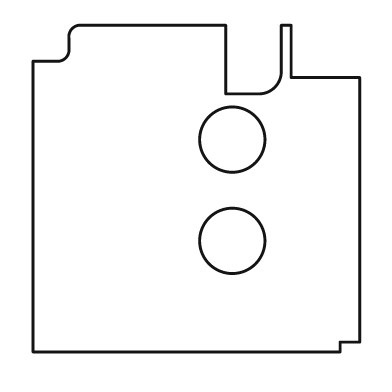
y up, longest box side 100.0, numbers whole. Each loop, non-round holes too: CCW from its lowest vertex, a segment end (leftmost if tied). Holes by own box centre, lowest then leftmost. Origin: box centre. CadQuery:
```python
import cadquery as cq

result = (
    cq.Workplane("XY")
    .moveTo(-50.0, -50.0)
    .lineTo(44.0, -50.0)
    .lineTo(44.0, -47.0)
    .lineTo(50.0, -47.0)
    .lineTo(50.0, 34.0)
    .lineTo(29.0, 34.0)
    .lineTo(29.0, 50.0)
    .lineTo(26.0, 50.0)
    .lineTo(26.0, 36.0)
    .threePointArc((24.0, 31.0), (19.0, 29.0))
    .lineTo(9.0, 29.0)
    .lineTo(9.0, 50.0)
    .lineTo(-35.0, 50.0)
    .threePointArc((-38.0, 49.0), (-39.0, 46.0))
    .lineTo(-39.0, 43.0)
    .threePointArc((-40.0, 40.0), (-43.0, 39.0))
    .lineTo(-50.0, 39.0)
    .close()
    .moveTo(11.0, -16.0)
    .circle(10.0)
    .moveTo(11.0, 15.0)
    .circle(10.0)
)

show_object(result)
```